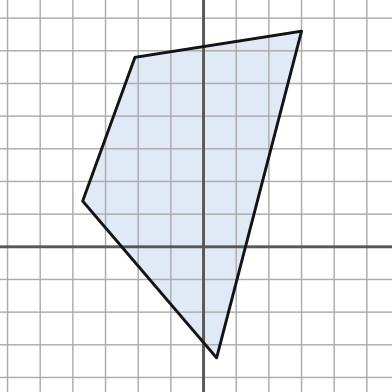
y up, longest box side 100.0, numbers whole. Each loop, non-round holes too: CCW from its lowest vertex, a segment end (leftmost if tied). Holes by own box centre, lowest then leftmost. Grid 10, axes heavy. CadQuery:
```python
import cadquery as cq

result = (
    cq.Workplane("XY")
    .moveTo(4.0, -34.0)
    .lineTo(30.0, 66.0)
    .lineTo(-21.0, 58.0)
    .lineTo(-37.0, 14.0)
    .close()
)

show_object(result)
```